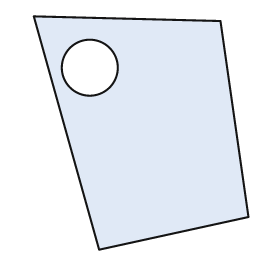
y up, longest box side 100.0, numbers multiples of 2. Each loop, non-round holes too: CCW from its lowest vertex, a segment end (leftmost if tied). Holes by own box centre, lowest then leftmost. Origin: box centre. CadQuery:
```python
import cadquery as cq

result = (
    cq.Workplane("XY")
    .moveTo(-18.0, -50.0)
    .lineTo(46.0, -36.0)
    .lineTo(34.0, 48.0)
    .lineTo(-46.0, 50.0)
    .close()
    .moveTo(-22.0, 28.0)
    .circle(12.0)
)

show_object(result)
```